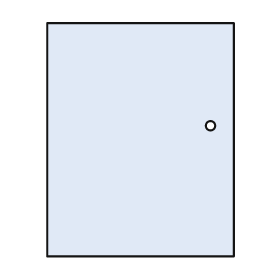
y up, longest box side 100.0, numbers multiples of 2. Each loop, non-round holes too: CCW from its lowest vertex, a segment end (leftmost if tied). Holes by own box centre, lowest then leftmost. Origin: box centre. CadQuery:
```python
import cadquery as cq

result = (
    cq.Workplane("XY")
    .moveTo(-40.0, -50.0)
    .lineTo(40.0, -50.0)
    .lineTo(40.0, 50.0)
    .lineTo(-40.0, 50.0)
    .close()
    .moveTo(30.0, 6.0)
    .circle(2.0)
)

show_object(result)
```